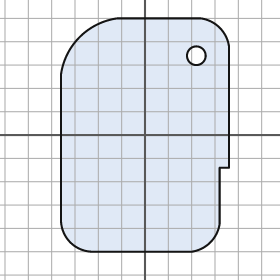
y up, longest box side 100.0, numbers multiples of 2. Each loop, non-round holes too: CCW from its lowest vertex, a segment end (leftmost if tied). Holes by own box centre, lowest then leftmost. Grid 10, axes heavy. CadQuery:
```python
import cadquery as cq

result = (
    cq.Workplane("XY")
    .moveTo(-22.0, -50.0)
    .lineTo(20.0, -50.0)
    .threePointArc((28.0, -46.0), (32.0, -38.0))
    .lineTo(32.0, -14.0)
    .lineTo(36.0, -14.0)
    .lineTo(36.0, 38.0)
    .threePointArc((32.0, 46.0), (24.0, 50.0))
    .lineTo(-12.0, 50.0)
    .threePointArc((-28.0, 42.0), (-36.0, 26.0))
    .lineTo(-36.0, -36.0)
    .threePointArc((-32.0, -46.0), (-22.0, -50.0))
    .close()
    .moveTo(22.0, 34.0)
    .circle(4.0)
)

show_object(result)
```